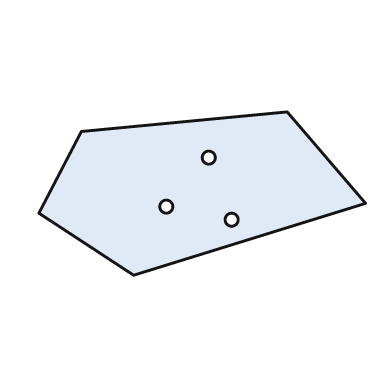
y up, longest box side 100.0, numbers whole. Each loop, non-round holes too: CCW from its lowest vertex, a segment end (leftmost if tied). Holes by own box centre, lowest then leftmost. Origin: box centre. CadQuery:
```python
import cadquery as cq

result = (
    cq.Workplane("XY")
    .moveTo(-21.0, -25.0)
    .lineTo(50.0, -3.0)
    .lineTo(26.0, 25.0)
    .lineTo(-37.0, 19.0)
    .lineTo(-50.0, -6.0)
    .close()
    .moveTo(9.0, -8.0)
    .circle(2.0)
    .moveTo(-11.0, -4.0)
    .circle(2.0)
    .moveTo(2.0, 11.0)
    .circle(2.0)
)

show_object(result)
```